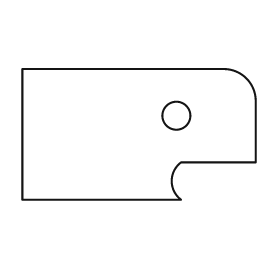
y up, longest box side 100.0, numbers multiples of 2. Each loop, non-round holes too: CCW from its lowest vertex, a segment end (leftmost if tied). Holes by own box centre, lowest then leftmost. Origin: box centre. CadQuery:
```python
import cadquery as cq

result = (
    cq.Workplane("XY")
    .moveTo(-50.0, -28.0)
    .lineTo(18.0, -28.0)
    .threePointArc((14.0, -20.0), (18.0, -12.0))
    .lineTo(50.0, -12.0)
    .lineTo(50.0, 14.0)
    .threePointArc((46.0, 24.0), (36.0, 28.0))
    .lineTo(-50.0, 28.0)
    .close()
    .moveTo(16.0, 8.0)
    .circle(6.0)
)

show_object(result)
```